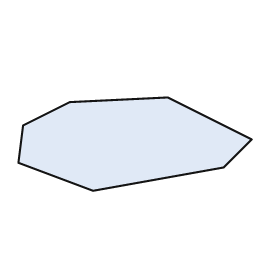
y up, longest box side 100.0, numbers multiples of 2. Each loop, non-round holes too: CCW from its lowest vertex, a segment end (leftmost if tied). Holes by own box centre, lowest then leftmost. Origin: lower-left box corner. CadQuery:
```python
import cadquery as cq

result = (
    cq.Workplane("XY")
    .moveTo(32.0, 0.0)
    .lineTo(88.0, 10.0)
    .lineTo(100.0, 22.0)
    .lineTo(64.0, 40.0)
    .lineTo(22.0, 38.0)
    .lineTo(2.0, 28.0)
    .lineTo(0.0, 12.0)
    .close()
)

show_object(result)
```